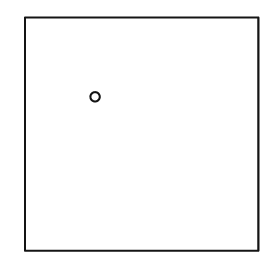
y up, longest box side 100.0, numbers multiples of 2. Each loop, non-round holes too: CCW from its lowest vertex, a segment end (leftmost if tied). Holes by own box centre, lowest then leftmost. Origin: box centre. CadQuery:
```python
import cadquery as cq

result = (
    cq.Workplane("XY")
    .moveTo(-50.0, -50.0)
    .lineTo(50.0, -50.0)
    .lineTo(50.0, 50.0)
    .lineTo(-50.0, 50.0)
    .close()
    .moveTo(-20.0, 16.0)
    .circle(2.0)
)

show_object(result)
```